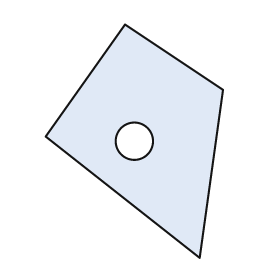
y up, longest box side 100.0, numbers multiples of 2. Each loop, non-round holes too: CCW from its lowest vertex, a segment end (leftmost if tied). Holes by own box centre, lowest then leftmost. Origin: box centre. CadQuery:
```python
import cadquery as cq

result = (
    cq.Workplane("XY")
    .moveTo(28.0, -50.0)
    .lineTo(38.0, 22.0)
    .lineTo(-4.0, 50.0)
    .lineTo(-38.0, 2.0)
    .close()
    .moveTo(0.0, 0.0)
    .circle(8.0)
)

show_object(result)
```